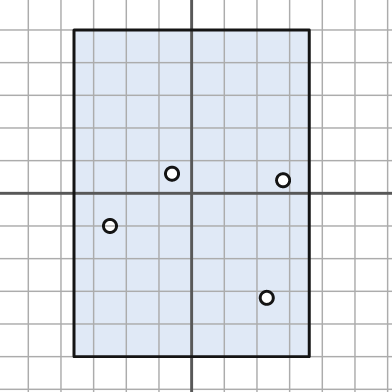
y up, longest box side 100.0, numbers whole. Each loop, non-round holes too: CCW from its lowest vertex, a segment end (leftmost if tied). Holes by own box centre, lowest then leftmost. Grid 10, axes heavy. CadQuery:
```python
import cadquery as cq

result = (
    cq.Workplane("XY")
    .moveTo(-36.0, -50.0)
    .lineTo(36.0, -50.0)
    .lineTo(36.0, 50.0)
    .lineTo(-36.0, 50.0)
    .close()
    .moveTo(23.0, -32.0)
    .circle(2.0)
    .moveTo(-25.0, -10.0)
    .circle(2.0)
    .moveTo(28.0, 4.0)
    .circle(2.0)
    .moveTo(-6.0, 6.0)
    .circle(2.0)
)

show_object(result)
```